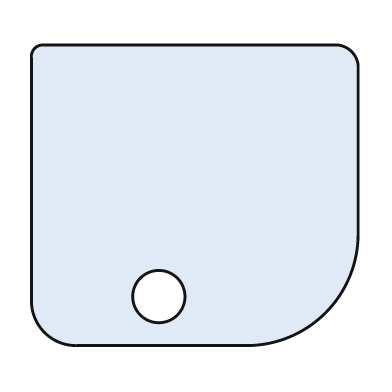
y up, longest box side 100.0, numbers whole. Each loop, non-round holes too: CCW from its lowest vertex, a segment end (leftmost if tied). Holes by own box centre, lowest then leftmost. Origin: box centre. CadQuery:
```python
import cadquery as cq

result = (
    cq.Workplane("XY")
    .moveTo(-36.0, -46.0)
    .lineTo(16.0, -46.0)
    .threePointArc((40.0, -36.0), (50.0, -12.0))
    .lineTo(50.0, 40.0)
    .threePointArc((48.0, 44.0), (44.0, 46.0))
    .lineTo(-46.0, 46.0)
    .threePointArc((-49.0, 45.0), (-50.0, 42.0))
    .lineTo(-50.0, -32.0)
    .threePointArc((-46.0, -42.0), (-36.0, -46.0))
    .close()
    .moveTo(-11.0, -31.0)
    .circle(8.0)
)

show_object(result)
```